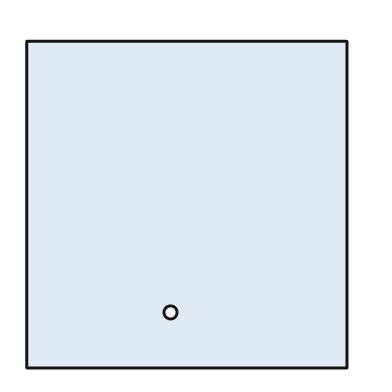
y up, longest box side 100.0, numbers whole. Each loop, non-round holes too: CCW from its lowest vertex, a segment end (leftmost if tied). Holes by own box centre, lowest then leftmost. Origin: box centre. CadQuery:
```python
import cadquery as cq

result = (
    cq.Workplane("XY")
    .moveTo(-49.0, -50.0)
    .lineTo(49.0, -50.0)
    .lineTo(49.0, 50.0)
    .lineTo(-49.0, 50.0)
    .close()
    .moveTo(-5.0, -33.0)
    .circle(2.0)
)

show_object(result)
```